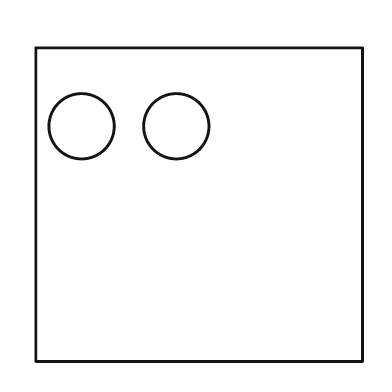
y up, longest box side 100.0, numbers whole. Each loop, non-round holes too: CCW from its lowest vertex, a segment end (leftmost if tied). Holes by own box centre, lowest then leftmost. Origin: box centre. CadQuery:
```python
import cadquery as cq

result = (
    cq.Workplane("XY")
    .moveTo(-50.0, -48.0)
    .lineTo(50.0, -48.0)
    .lineTo(50.0, 48.0)
    .lineTo(-50.0, 48.0)
    .close()
    .moveTo(-36.0, 24.0)
    .circle(10.0)
    .moveTo(-7.0, 24.0)
    .circle(10.0)
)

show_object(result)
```